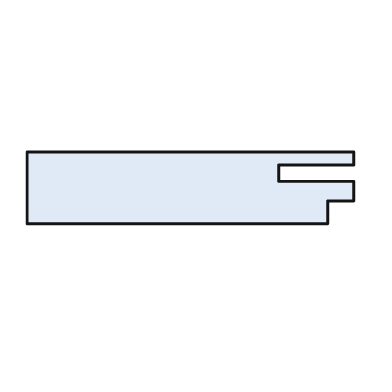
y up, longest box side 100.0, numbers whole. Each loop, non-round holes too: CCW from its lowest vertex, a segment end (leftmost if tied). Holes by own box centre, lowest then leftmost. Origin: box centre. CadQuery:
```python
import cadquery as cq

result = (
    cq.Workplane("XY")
    .moveTo(-50.0, -11.0)
    .lineTo(42.0, -11.0)
    .lineTo(42.0, -4.0)
    .lineTo(50.0, -4.0)
    .lineTo(50.0, 2.0)
    .lineTo(27.0, 2.0)
    .lineTo(27.0, 7.0)
    .lineTo(50.0, 7.0)
    .lineTo(50.0, 11.0)
    .lineTo(-50.0, 11.0)
    .close()
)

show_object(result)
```